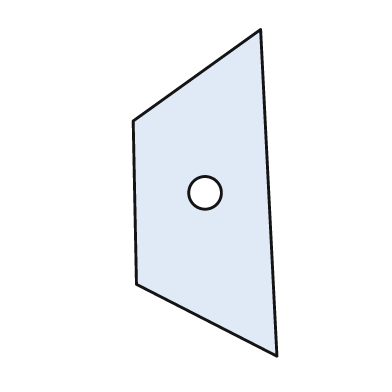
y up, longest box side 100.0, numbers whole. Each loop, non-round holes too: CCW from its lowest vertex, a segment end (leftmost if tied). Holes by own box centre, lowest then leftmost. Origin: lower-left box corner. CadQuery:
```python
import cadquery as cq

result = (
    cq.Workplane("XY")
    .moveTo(44.0, 0.0)
    .lineTo(39.0, 100.0)
    .lineTo(0.0, 72.0)
    .lineTo(1.0, 22.0)
    .close()
    .moveTo(22.0, 50.0)
    .circle(5.0)
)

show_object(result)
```